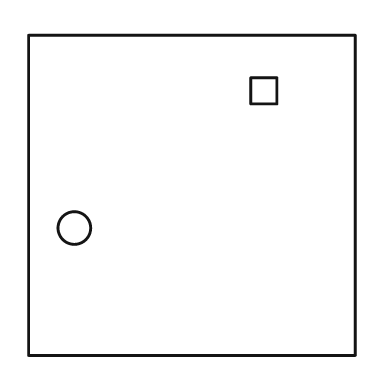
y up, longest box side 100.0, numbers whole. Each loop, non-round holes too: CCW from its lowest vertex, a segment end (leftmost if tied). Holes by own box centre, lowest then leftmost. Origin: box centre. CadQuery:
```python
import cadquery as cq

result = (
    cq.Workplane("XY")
    .moveTo(-50.0, -49.0)
    .lineTo(50.0, -49.0)
    .lineTo(50.0, 49.0)
    .lineTo(-50.0, 49.0)
    .close()
    .moveTo(-36.0, -10.0)
    .circle(5.0)
    .moveTo(18.0, 28.0)
    .lineTo(26.0, 28.0)
    .lineTo(26.0, 36.0)
    .lineTo(18.0, 36.0)
    .close()
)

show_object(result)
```